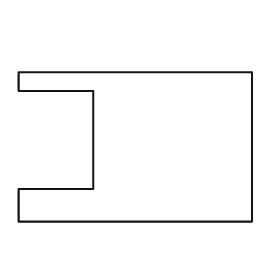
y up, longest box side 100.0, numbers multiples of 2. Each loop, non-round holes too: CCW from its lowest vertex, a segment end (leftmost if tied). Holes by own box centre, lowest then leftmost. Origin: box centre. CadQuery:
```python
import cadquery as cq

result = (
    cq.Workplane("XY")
    .moveTo(-50.0, -32.0)
    .lineTo(50.0, -32.0)
    .lineTo(50.0, 32.0)
    .lineTo(-50.0, 32.0)
    .lineTo(-50.0, 24.0)
    .lineTo(-18.0, 24.0)
    .lineTo(-18.0, -18.0)
    .lineTo(-50.0, -18.0)
    .close()
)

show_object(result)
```